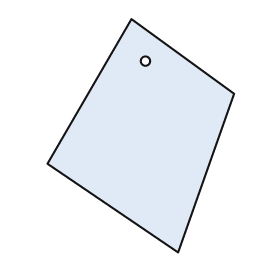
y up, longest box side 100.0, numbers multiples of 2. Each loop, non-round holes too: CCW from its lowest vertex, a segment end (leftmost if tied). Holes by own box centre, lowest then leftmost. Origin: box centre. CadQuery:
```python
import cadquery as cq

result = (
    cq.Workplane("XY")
    .moveTo(16.0, -50.0)
    .lineTo(40.0, 18.0)
    .lineTo(-4.0, 50.0)
    .lineTo(-40.0, -12.0)
    .close()
    .moveTo(2.0, 32.0)
    .circle(2.0)
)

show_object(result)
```